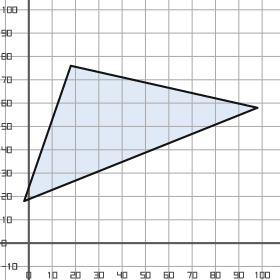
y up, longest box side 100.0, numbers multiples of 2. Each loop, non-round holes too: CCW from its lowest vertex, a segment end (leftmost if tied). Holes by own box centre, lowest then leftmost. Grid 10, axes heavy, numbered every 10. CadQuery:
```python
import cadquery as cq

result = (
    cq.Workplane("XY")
    .moveTo(-2.0, 18.0)
    .lineTo(98.0, 58.0)
    .lineTo(18.0, 76.0)
    .close()
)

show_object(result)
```